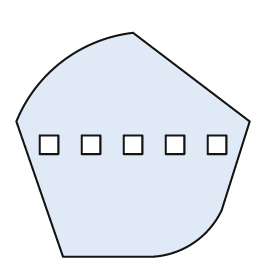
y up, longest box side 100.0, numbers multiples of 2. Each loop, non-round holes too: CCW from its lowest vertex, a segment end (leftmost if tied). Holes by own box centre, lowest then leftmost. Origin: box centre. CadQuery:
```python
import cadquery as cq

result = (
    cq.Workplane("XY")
    .moveTo(-30.0, -48.0)
    .lineTo(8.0, -48.0)
    .threePointArc((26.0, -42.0), (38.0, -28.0))
    .lineTo(50.0, 10.0)
    .lineTo(0.0, 48.0)
    .threePointArc((-30.0, 36.0), (-50.0, 10.0))
    .close()
    .moveTo(-40.0, -4.0)
    .lineTo(-32.0, -4.0)
    .lineTo(-32.0, 4.0)
    .lineTo(-40.0, 4.0)
    .close()
    .moveTo(-22.0, -4.0)
    .lineTo(-14.0, -4.0)
    .lineTo(-14.0, 4.0)
    .lineTo(-22.0, 4.0)
    .close()
    .moveTo(-4.0, -4.0)
    .lineTo(4.0, -4.0)
    .lineTo(4.0, 4.0)
    .lineTo(-4.0, 4.0)
    .close()
    .moveTo(14.0, -4.0)
    .lineTo(22.0, -4.0)
    .lineTo(22.0, 4.0)
    .lineTo(14.0, 4.0)
    .close()
    .moveTo(32.0, -4.0)
    .lineTo(40.0, -4.0)
    .lineTo(40.0, 4.0)
    .lineTo(32.0, 4.0)
    .close()
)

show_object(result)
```